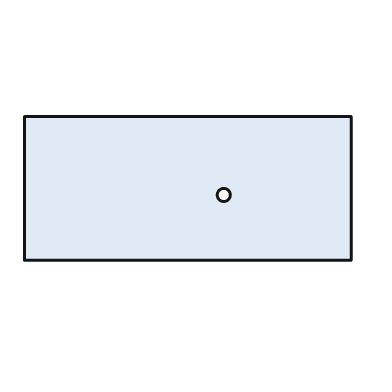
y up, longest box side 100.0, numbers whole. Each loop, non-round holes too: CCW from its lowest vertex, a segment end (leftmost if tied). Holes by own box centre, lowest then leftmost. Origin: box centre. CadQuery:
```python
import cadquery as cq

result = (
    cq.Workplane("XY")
    .moveTo(-50.0, -22.0)
    .lineTo(50.0, -22.0)
    .lineTo(50.0, 22.0)
    .lineTo(-50.0, 22.0)
    .close()
    .moveTo(11.0, -2.0)
    .circle(2.0)
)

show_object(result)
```